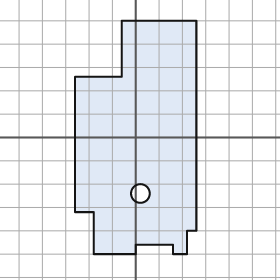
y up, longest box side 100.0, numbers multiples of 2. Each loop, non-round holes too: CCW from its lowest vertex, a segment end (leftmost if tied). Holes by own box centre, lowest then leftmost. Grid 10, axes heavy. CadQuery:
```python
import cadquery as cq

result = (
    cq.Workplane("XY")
    .moveTo(-18.0, -50.0)
    .lineTo(0.0, -50.0)
    .lineTo(0.0, -46.0)
    .lineTo(16.0, -46.0)
    .lineTo(16.0, -50.0)
    .lineTo(22.0, -50.0)
    .lineTo(22.0, -40.0)
    .lineTo(26.0, -40.0)
    .lineTo(26.0, 50.0)
    .lineTo(-6.0, 50.0)
    .lineTo(-6.0, 26.0)
    .lineTo(-26.0, 26.0)
    .lineTo(-26.0, -32.0)
    .lineTo(-18.0, -32.0)
    .close()
    .moveTo(2.0, -24.0)
    .circle(4.0)
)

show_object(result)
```